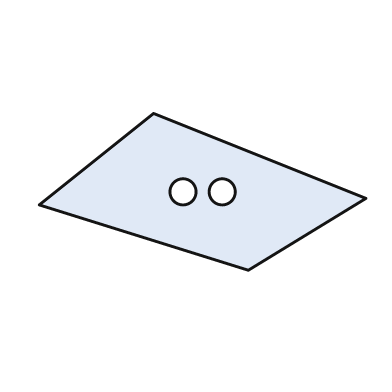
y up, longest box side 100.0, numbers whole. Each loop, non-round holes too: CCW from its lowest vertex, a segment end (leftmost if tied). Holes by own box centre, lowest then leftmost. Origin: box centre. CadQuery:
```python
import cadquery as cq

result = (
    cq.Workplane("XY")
    .moveTo(14.0, -24.0)
    .lineTo(50.0, -2.0)
    .lineTo(-15.0, 24.0)
    .lineTo(-50.0, -4.0)
    .close()
    .moveTo(-6.0, 0.0)
    .circle(4.0)
    .moveTo(6.0, 0.0)
    .circle(4.0)
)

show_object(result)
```